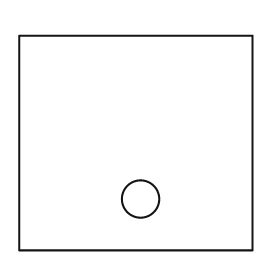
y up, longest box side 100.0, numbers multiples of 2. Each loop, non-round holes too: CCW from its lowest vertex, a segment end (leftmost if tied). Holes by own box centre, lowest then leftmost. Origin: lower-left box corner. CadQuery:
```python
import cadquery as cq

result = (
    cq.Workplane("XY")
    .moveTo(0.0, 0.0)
    .lineTo(100.0, 0.0)
    .lineTo(100.0, 92.0)
    .lineTo(0.0, 92.0)
    .close()
    .moveTo(52.0, 22.0)
    .circle(8.0)
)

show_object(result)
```